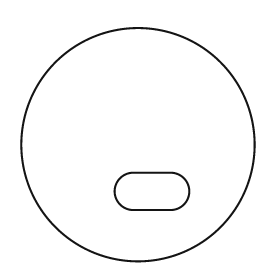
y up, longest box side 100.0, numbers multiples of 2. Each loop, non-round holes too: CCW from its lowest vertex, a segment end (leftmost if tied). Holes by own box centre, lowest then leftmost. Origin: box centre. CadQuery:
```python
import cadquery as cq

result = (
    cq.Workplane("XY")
    .moveTo(0.0, 0.0)
    .circle(50.0)
    .moveTo(-2.0, -28.0)
    .lineTo(14.0, -28.0)
    .threePointArc((22.0, -20.0), (14.0, -12.0))
    .lineTo(-2.0, -12.0)
    .threePointArc((-10.0, -20.0), (-2.0, -28.0))
    .close()
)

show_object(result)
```